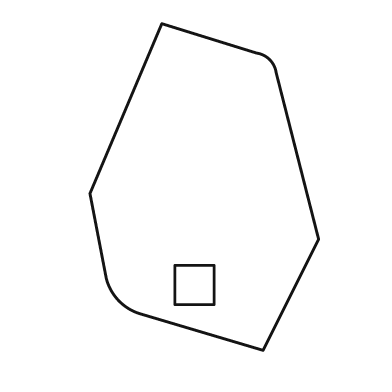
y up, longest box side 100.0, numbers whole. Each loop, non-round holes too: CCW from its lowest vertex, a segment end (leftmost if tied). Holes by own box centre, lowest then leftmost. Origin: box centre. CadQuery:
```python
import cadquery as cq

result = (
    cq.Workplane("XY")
    .moveTo(18.0, -50.0)
    .lineTo(35.0, -16.0)
    .lineTo(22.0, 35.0)
    .threePointArc((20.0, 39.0), (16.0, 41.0))
    .lineTo(-13.0, 50.0)
    .lineTo(-35.0, -2.0)
    .lineTo(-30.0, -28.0)
    .threePointArc((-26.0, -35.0), (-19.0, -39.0))
    .close()
    .moveTo(-9.0, -36.0)
    .lineTo(3.0, -36.0)
    .lineTo(3.0, -24.0)
    .lineTo(-9.0, -24.0)
    .close()
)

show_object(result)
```